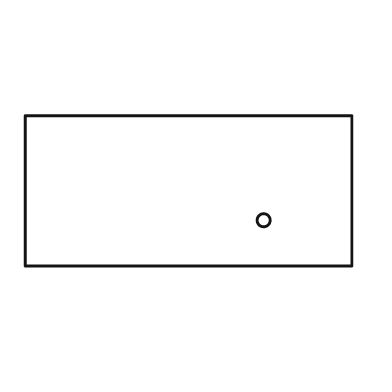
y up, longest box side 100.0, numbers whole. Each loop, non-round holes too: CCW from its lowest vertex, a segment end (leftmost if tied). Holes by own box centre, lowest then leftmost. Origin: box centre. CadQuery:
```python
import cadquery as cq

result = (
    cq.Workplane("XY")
    .moveTo(-50.0, -23.0)
    .lineTo(50.0, -23.0)
    .lineTo(50.0, 23.0)
    .lineTo(-50.0, 23.0)
    .close()
    .moveTo(23.0, -9.0)
    .circle(2.0)
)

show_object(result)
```